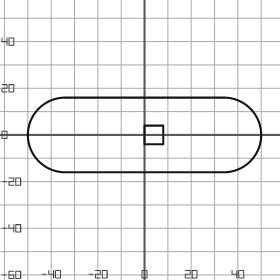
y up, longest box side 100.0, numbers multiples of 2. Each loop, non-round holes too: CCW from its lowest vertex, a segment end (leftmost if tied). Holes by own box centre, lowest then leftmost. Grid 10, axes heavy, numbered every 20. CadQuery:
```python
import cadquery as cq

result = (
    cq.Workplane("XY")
    .moveTo(-34.0, -16.0)
    .lineTo(34.0, -16.0)
    .threePointArc((50.0, 0.0), (34.0, 16.0))
    .lineTo(-34.0, 16.0)
    .threePointArc((-50.0, 0.0), (-34.0, -16.0))
    .close()
    .moveTo(0.0, -4.0)
    .lineTo(8.0, -4.0)
    .lineTo(8.0, 4.0)
    .lineTo(0.0, 4.0)
    .close()
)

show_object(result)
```